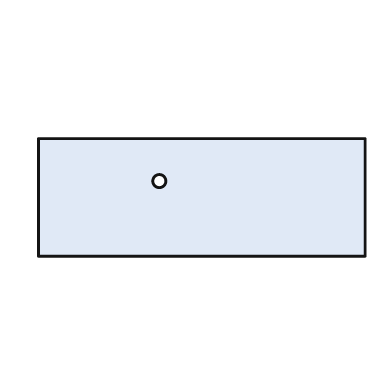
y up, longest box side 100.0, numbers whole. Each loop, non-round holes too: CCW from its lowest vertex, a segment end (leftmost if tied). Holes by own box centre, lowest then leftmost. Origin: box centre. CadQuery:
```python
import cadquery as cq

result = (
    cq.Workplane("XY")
    .moveTo(-50.0, -18.0)
    .lineTo(50.0, -18.0)
    .lineTo(50.0, 18.0)
    .lineTo(-50.0, 18.0)
    .close()
    .moveTo(-13.0, 5.0)
    .circle(2.0)
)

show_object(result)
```